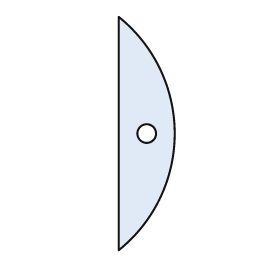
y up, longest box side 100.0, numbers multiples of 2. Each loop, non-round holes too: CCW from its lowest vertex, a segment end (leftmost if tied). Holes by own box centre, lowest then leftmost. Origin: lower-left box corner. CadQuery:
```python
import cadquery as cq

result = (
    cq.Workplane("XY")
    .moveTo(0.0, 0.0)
    .threePointArc((24.0, 50.0), (0.0, 100.0))
    .close()
    .moveTo(12.0, 50.0)
    .circle(4.0)
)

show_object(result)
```